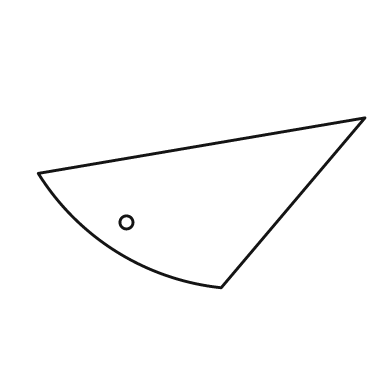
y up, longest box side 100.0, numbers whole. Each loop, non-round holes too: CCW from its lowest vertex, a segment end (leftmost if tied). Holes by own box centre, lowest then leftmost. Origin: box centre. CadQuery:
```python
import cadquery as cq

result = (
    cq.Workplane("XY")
    .moveTo(6.0, -26.0)
    .lineTo(50.0, 26.0)
    .lineTo(-50.0, 9.0)
    .threePointArc((-26.0, -15.0), (6.0, -26.0))
    .close()
    .moveTo(-23.0, -6.0)
    .circle(2.0)
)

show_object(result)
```